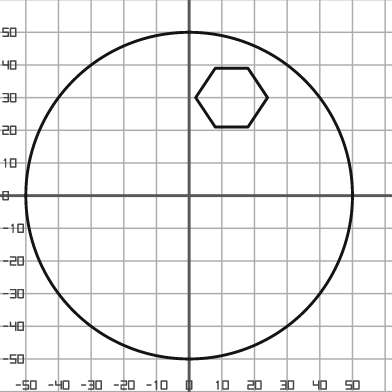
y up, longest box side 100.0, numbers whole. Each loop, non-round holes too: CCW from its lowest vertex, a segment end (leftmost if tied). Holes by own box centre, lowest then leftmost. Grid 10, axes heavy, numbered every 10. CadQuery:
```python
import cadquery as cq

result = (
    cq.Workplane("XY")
    .moveTo(0.0, 0.0)
    .circle(50.0)
    .moveTo(8.0, 21.0)
    .lineTo(18.0, 21.0)
    .lineTo(24.0, 30.0)
    .lineTo(18.0, 39.0)
    .lineTo(8.0, 39.0)
    .lineTo(2.0, 30.0)
    .close()
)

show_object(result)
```